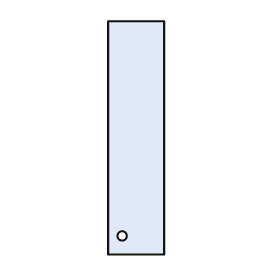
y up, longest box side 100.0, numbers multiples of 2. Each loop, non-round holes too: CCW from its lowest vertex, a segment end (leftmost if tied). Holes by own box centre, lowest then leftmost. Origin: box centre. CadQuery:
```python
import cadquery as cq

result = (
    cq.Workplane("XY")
    .moveTo(-12.0, -50.0)
    .lineTo(12.0, -50.0)
    .lineTo(12.0, 50.0)
    .lineTo(-12.0, 50.0)
    .close()
    .moveTo(-6.0, -42.0)
    .circle(2.0)
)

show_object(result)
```